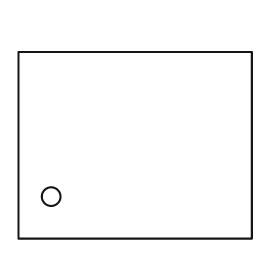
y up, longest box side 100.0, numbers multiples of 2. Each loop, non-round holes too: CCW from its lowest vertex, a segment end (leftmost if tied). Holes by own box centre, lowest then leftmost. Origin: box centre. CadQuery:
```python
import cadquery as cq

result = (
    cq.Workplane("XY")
    .moveTo(-50.0, -40.0)
    .lineTo(50.0, -40.0)
    .lineTo(50.0, 40.0)
    .lineTo(-50.0, 40.0)
    .close()
    .moveTo(-36.0, -22.0)
    .circle(4.0)
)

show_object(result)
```